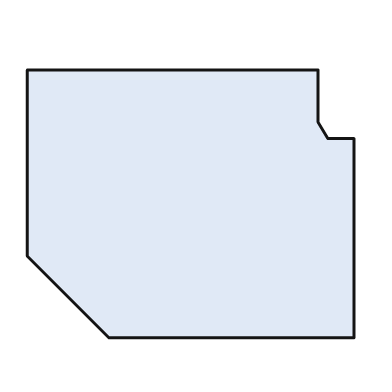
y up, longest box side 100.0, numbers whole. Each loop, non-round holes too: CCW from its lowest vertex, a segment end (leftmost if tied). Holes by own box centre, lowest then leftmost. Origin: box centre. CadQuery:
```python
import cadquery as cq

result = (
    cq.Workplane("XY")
    .moveTo(-25.0, -41.0)
    .lineTo(50.0, -41.0)
    .lineTo(50.0, 20.0)
    .lineTo(42.0, 20.0)
    .lineTo(39.0, 25.0)
    .lineTo(39.0, 41.0)
    .lineTo(-50.0, 41.0)
    .lineTo(-50.0, -16.0)
    .close()
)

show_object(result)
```